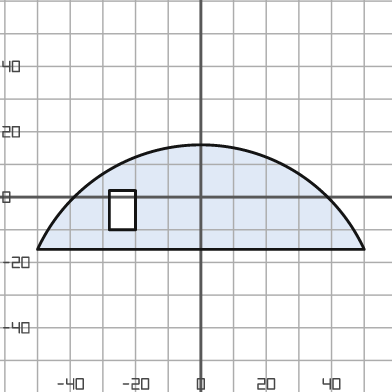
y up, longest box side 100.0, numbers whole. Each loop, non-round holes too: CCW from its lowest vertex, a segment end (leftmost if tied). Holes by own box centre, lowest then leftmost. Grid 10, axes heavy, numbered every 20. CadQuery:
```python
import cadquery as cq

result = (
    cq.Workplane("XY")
    .moveTo(-50.0, -16.0)
    .lineTo(50.0, -16.0)
    .threePointArc((0.0, 16.0), (-50.0, -16.0))
    .close()
    .moveTo(-28.0, -10.0)
    .lineTo(-20.0, -10.0)
    .lineTo(-20.0, 2.0)
    .lineTo(-28.0, 2.0)
    .close()
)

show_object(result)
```